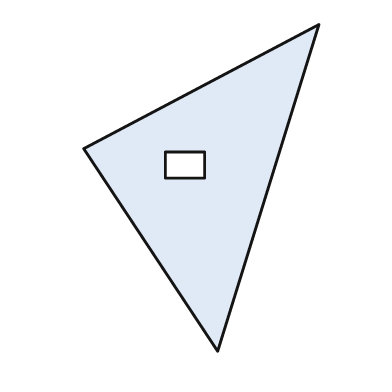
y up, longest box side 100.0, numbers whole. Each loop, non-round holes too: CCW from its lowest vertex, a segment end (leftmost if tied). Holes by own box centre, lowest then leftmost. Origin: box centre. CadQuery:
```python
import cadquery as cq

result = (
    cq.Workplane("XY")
    .moveTo(5.0, -50.0)
    .lineTo(36.0, 50.0)
    .lineTo(-36.0, 12.0)
    .close()
    .moveTo(-11.0, 3.0)
    .lineTo(1.0, 3.0)
    .lineTo(1.0, 11.0)
    .lineTo(-11.0, 11.0)
    .close()
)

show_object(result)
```